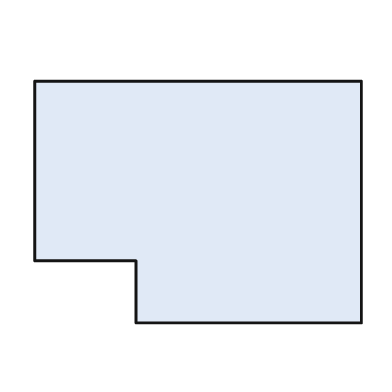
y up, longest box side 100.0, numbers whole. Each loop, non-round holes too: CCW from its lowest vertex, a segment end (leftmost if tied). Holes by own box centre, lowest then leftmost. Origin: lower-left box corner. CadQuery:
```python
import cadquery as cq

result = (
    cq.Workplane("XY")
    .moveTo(31.0, 0.0)
    .lineTo(100.0, 0.0)
    .lineTo(100.0, 74.0)
    .lineTo(0.0, 74.0)
    .lineTo(0.0, 19.0)
    .lineTo(31.0, 19.0)
    .close()
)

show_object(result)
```